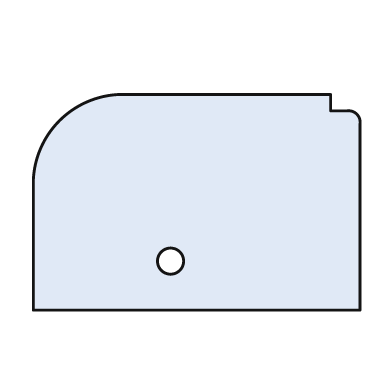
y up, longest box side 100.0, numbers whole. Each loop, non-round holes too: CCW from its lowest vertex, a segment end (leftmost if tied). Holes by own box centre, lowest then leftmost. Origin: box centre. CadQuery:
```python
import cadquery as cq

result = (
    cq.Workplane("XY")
    .moveTo(-50.0, -33.0)
    .lineTo(50.0, -33.0)
    .lineTo(50.0, 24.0)
    .threePointArc((49.0, 27.0), (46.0, 28.0))
    .lineTo(41.0, 28.0)
    .lineTo(41.0, 33.0)
    .lineTo(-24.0, 33.0)
    .threePointArc((-42.0, 25.0), (-50.0, 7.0))
    .close()
    .moveTo(-8.0, -18.0)
    .circle(4.0)
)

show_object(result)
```